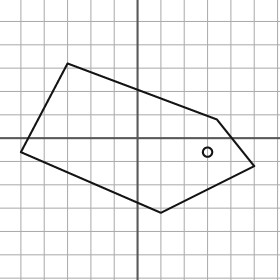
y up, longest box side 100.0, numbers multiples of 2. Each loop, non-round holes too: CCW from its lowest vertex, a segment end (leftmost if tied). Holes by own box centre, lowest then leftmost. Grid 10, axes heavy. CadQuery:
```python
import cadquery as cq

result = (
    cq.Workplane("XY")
    .moveTo(10.0, -32.0)
    .lineTo(50.0, -12.0)
    .lineTo(34.0, 8.0)
    .lineTo(-30.0, 32.0)
    .lineTo(-50.0, -6.0)
    .close()
    .moveTo(30.0, -6.0)
    .circle(2.0)
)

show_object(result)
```